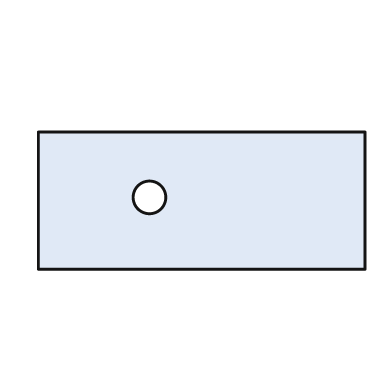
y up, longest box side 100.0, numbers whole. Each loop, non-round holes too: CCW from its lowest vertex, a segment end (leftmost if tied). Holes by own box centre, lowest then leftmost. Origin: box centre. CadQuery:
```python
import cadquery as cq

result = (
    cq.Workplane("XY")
    .moveTo(-50.0, -21.0)
    .lineTo(50.0, -21.0)
    .lineTo(50.0, 21.0)
    .lineTo(-50.0, 21.0)
    .close()
    .moveTo(-16.0, 1.0)
    .circle(5.0)
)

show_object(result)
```